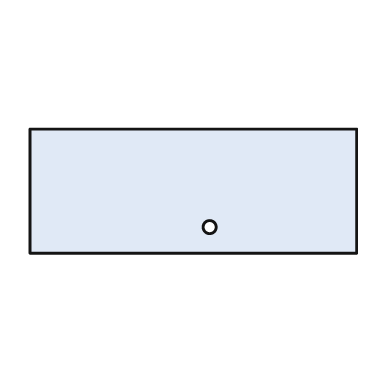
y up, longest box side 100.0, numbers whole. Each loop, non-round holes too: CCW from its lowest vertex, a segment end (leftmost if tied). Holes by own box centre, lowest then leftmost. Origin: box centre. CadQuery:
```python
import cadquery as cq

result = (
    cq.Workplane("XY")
    .moveTo(-50.0, -19.0)
    .lineTo(50.0, -19.0)
    .lineTo(50.0, 19.0)
    .lineTo(-50.0, 19.0)
    .close()
    .moveTo(5.0, -11.0)
    .circle(2.0)
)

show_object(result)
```